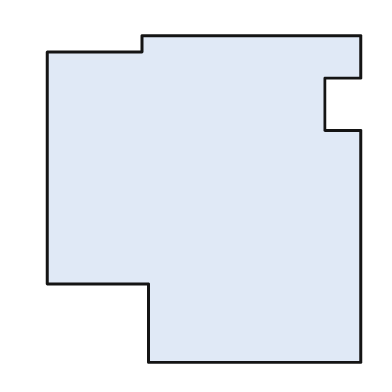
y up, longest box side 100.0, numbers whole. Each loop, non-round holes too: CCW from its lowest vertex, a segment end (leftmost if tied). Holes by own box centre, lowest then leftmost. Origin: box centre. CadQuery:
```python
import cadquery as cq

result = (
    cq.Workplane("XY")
    .moveTo(-17.0, -50.0)
    .lineTo(48.0, -50.0)
    .lineTo(48.0, 21.0)
    .lineTo(37.0, 21.0)
    .lineTo(37.0, 37.0)
    .lineTo(48.0, 37.0)
    .lineTo(48.0, 50.0)
    .lineTo(-19.0, 50.0)
    .lineTo(-19.0, 45.0)
    .lineTo(-48.0, 45.0)
    .lineTo(-48.0, -26.0)
    .lineTo(-17.0, -26.0)
    .close()
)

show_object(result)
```